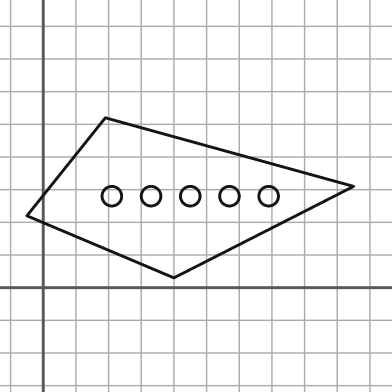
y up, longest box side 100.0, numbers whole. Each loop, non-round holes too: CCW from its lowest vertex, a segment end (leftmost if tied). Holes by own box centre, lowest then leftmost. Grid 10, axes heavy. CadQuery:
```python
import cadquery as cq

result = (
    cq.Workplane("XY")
    .moveTo(40.0, 3.0)
    .lineTo(95.0, 31.0)
    .lineTo(19.0, 52.0)
    .lineTo(-5.0, 22.0)
    .close()
    .moveTo(21.0, 28.0)
    .circle(3.0)
    .moveTo(33.0, 28.0)
    .circle(3.0)
    .moveTo(45.0, 28.0)
    .circle(3.0)
    .moveTo(57.0, 28.0)
    .circle(3.0)
    .moveTo(69.0, 28.0)
    .circle(3.0)
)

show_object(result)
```